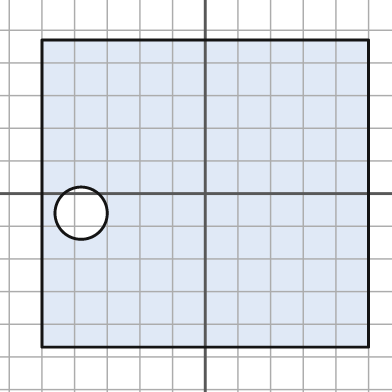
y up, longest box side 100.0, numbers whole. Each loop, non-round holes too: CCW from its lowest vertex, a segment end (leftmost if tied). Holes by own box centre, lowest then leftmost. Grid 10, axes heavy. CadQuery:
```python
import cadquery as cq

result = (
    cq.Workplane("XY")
    .moveTo(-50.0, -47.0)
    .lineTo(50.0, -47.0)
    .lineTo(50.0, 47.0)
    .lineTo(-50.0, 47.0)
    .close()
    .moveTo(-38.0, -6.0)
    .circle(8.0)
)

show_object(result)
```